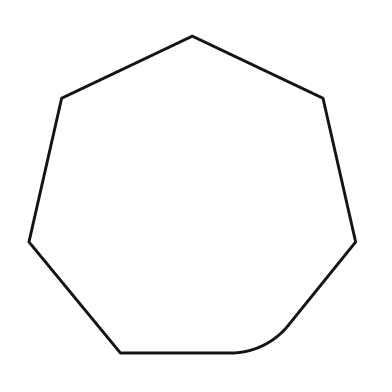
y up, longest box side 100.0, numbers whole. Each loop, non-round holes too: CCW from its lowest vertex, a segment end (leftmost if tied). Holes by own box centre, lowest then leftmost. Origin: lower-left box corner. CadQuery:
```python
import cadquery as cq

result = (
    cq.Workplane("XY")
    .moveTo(28.0, 0.0)
    .lineTo(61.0, 0.0)
    .threePointArc((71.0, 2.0), (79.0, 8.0))
    .lineTo(100.0, 34.0)
    .lineTo(90.0, 78.0)
    .lineTo(50.0, 97.0)
    .lineTo(10.0, 78.0)
    .lineTo(0.0, 34.0)
    .close()
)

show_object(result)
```